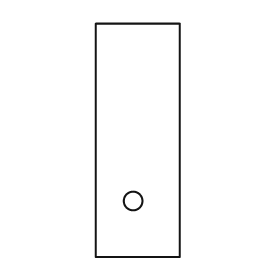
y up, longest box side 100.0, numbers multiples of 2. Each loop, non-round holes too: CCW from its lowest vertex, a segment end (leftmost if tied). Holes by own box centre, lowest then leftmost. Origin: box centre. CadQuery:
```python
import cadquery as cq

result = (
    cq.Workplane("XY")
    .moveTo(-18.0, -50.0)
    .lineTo(18.0, -50.0)
    .lineTo(18.0, 50.0)
    .lineTo(-18.0, 50.0)
    .close()
    .moveTo(-2.0, -26.0)
    .circle(4.0)
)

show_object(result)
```